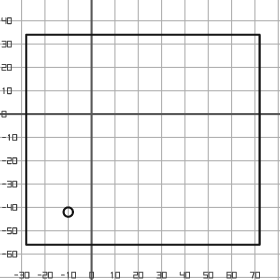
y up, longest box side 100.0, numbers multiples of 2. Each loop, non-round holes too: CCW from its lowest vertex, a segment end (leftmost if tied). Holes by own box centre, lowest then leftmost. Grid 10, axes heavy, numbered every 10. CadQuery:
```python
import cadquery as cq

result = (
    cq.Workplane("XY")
    .moveTo(-28.0, -56.0)
    .lineTo(72.0, -56.0)
    .lineTo(72.0, 34.0)
    .lineTo(-28.0, 34.0)
    .close()
    .moveTo(-10.0, -42.0)
    .circle(2.0)
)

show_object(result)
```